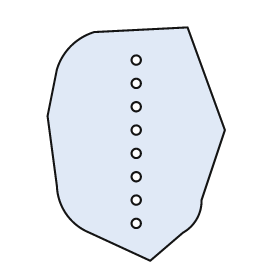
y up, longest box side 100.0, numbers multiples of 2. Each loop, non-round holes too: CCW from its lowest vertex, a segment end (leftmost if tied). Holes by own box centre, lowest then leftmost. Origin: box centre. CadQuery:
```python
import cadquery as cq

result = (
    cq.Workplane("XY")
    .moveTo(6.0, -50.0)
    .lineTo(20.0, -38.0)
    .threePointArc((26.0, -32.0), (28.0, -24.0))
    .lineTo(38.0, 6.0)
    .lineTo(22.0, 50.0)
    .lineTo(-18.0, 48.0)
    .threePointArc((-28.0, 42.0), (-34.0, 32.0))
    .lineTo(-38.0, 12.0)
    .lineTo(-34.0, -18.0)
    .threePointArc((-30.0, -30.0), (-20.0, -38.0))
    .close()
    .moveTo(0.0, -34.0)
    .circle(2.0)
    .moveTo(0.0, -24.0)
    .circle(2.0)
    .moveTo(0.0, -14.0)
    .circle(2.0)
    .moveTo(0.0, -4.0)
    .circle(2.0)
    .moveTo(0.0, 6.0)
    .circle(2.0)
    .moveTo(0.0, 16.0)
    .circle(2.0)
    .moveTo(0.0, 26.0)
    .circle(2.0)
    .moveTo(0.0, 36.0)
    .circle(2.0)
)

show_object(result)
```